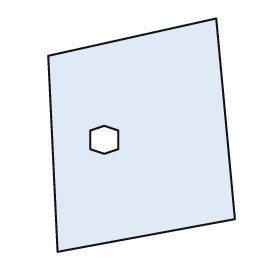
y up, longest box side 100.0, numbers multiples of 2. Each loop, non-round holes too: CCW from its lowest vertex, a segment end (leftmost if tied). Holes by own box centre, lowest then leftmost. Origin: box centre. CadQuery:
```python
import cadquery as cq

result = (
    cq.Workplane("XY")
    .moveTo(-36.0, -50.0)
    .lineTo(40.0, -36.0)
    .lineTo(32.0, 50.0)
    .lineTo(-40.0, 34.0)
    .close()
    .moveTo(-16.0, -8.0)
    .lineTo(-10.0, -6.0)
    .lineTo(-10.0, 2.0)
    .lineTo(-16.0, 4.0)
    .lineTo(-22.0, 2.0)
    .lineTo(-22.0, -6.0)
    .close()
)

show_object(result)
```